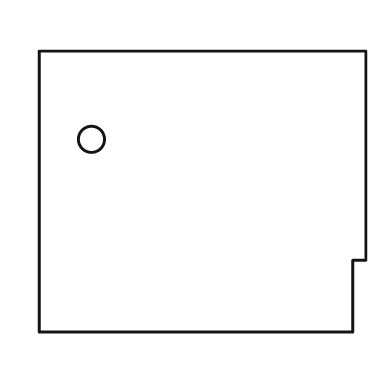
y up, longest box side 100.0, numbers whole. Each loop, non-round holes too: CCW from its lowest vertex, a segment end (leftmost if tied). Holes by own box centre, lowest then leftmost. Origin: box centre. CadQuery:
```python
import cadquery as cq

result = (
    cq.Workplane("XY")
    .moveTo(-50.0, -43.0)
    .lineTo(46.0, -43.0)
    .lineTo(46.0, -21.0)
    .lineTo(50.0, -21.0)
    .lineTo(50.0, 43.0)
    .lineTo(-50.0, 43.0)
    .close()
    .moveTo(-34.0, 16.0)
    .circle(4.0)
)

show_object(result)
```